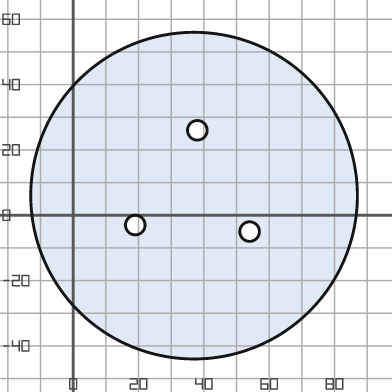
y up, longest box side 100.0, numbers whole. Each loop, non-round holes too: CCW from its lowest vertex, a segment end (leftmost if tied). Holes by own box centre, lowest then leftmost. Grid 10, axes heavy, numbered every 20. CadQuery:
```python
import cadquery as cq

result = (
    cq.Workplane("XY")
    .moveTo(37.0, 6.0)
    .circle(50.0)
    .moveTo(54.0, -5.0)
    .circle(3.0)
    .moveTo(19.0, -3.0)
    .circle(3.0)
    .moveTo(38.0, 26.0)
    .circle(3.0)
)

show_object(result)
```